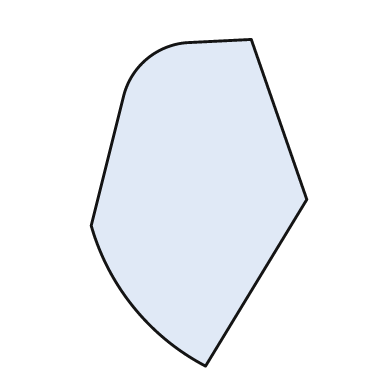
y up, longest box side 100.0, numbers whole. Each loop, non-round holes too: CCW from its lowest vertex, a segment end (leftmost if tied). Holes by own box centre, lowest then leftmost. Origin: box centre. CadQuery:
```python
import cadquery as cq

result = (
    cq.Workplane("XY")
    .moveTo(2.0, -50.0)
    .lineTo(33.0, 1.0)
    .lineTo(16.0, 50.0)
    .lineTo(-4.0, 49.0)
    .threePointArc((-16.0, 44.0), (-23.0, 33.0))
    .lineTo(-33.0, -7.0)
    .threePointArc((-20.0, -32.0), (2.0, -50.0))
    .close()
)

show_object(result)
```